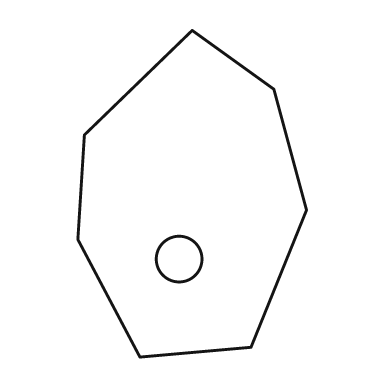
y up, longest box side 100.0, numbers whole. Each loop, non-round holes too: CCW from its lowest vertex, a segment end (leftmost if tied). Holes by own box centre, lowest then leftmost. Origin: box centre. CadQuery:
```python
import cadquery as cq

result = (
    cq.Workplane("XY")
    .moveTo(-16.0, -50.0)
    .lineTo(18.0, -47.0)
    .lineTo(35.0, -5.0)
    .lineTo(25.0, 32.0)
    .lineTo(0.0, 50.0)
    .lineTo(-33.0, 18.0)
    .lineTo(-35.0, -14.0)
    .close()
    .moveTo(-4.0, -20.0)
    .circle(7.0)
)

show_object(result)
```